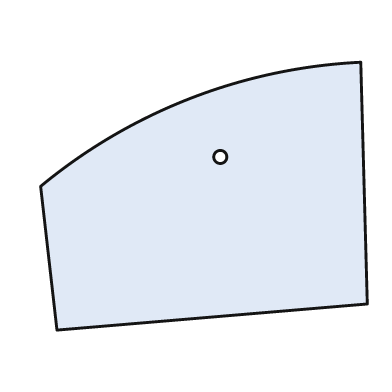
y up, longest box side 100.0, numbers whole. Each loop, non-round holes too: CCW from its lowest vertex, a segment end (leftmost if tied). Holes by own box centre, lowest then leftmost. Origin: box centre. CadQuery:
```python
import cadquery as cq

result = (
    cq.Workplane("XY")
    .moveTo(-45.0, -41.0)
    .lineTo(50.0, -33.0)
    .lineTo(48.0, 41.0)
    .threePointArc((-4.0, 30.0), (-50.0, 3.0))
    .close()
    .moveTo(5.0, 12.0)
    .circle(2.0)
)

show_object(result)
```